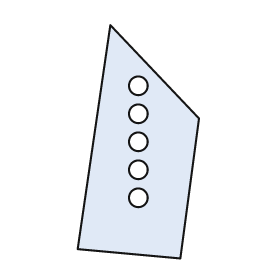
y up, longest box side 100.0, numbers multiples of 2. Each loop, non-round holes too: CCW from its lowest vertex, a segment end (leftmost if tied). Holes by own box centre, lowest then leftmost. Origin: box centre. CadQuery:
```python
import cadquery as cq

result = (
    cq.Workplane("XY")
    .moveTo(18.0, -50.0)
    .lineTo(26.0, 10.0)
    .lineTo(-12.0, 50.0)
    .lineTo(-26.0, -46.0)
    .close()
    .moveTo(0.0, -24.0)
    .circle(4.0)
    .moveTo(0.0, -12.0)
    .circle(4.0)
    .moveTo(0.0, 0.0)
    .circle(4.0)
    .moveTo(0.0, 12.0)
    .circle(4.0)
    .moveTo(0.0, 24.0)
    .circle(4.0)
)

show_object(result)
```